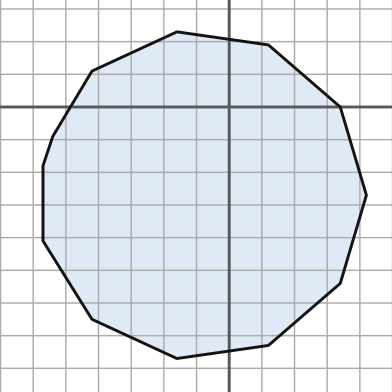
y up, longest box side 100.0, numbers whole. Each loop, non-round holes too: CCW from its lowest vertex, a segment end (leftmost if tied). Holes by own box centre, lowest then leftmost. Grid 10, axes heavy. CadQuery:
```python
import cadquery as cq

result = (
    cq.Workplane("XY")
    .moveTo(-16.0, -77.0)
    .lineTo(12.0, -73.0)
    .lineTo(34.0, -54.0)
    .lineTo(42.0, -27.0)
    .lineTo(34.0, 0.0)
    .lineTo(12.0, 19.0)
    .lineTo(-16.0, 23.0)
    .lineTo(-42.0, 11.0)
    .lineTo(-54.0, -9.0)
    .lineTo(-57.0, -18.0)
    .lineTo(-57.0, -41.0)
    .lineTo(-42.0, -65.0)
    .close()
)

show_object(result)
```